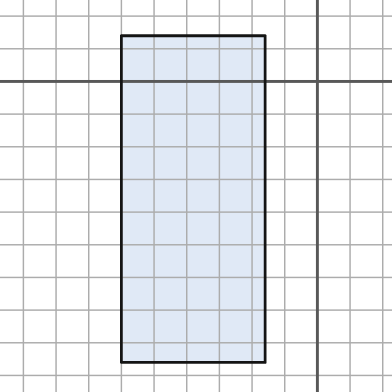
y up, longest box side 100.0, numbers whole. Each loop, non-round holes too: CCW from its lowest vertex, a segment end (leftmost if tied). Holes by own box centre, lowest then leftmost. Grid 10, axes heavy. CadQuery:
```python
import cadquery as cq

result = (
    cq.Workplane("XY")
    .moveTo(-60.0, -86.0)
    .lineTo(-16.0, -86.0)
    .lineTo(-16.0, 14.0)
    .lineTo(-60.0, 14.0)
    .close()
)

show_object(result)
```